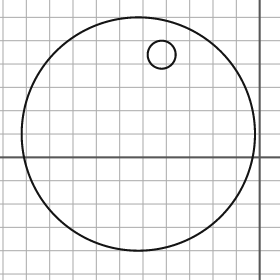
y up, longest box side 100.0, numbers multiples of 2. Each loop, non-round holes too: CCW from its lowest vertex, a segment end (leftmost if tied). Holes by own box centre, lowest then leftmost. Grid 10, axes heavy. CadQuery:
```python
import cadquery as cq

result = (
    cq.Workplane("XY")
    .moveTo(-52.0, 10.0)
    .circle(50.0)
    .moveTo(-42.0, 44.0)
    .circle(6.0)
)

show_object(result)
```